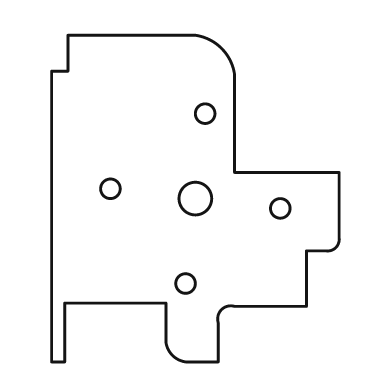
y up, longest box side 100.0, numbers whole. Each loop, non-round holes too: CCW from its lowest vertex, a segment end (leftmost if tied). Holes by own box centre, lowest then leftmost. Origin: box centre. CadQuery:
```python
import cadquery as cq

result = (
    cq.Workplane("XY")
    .moveTo(-44.0, -50.0)
    .lineTo(-40.0, -50.0)
    .lineTo(-40.0, -32.0)
    .lineTo(-9.0, -32.0)
    .lineTo(-9.0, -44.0)
    .threePointArc((-7.0, -48.0), (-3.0, -50.0))
    .lineTo(7.0, -50.0)
    .lineTo(7.0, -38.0)
    .threePointArc((8.0, -34.0), (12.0, -33.0))
    .lineTo(34.0, -33.0)
    .lineTo(34.0, -16.0)
    .lineTo(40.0, -16.0)
    .threePointArc((43.0, -15.0), (44.0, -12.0))
    .lineTo(44.0, 8.0)
    .lineTo(12.0, 8.0)
    .lineTo(12.0, 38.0)
    .threePointArc((8.0, 46.0), (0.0, 50.0))
    .lineTo(-39.0, 50.0)
    .lineTo(-39.0, 39.0)
    .lineTo(-44.0, 39.0)
    .close()
    .moveTo(-3.0, -26.0)
    .circle(3.0)
    .moveTo(26.0, -3.0)
    .circle(3.0)
    .moveTo(0.0, 0.0)
    .circle(5.0)
    .moveTo(-26.0, 3.0)
    .circle(3.0)
    .moveTo(3.0, 26.0)
    .circle(3.0)
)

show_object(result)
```